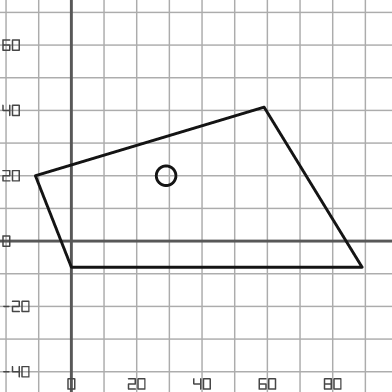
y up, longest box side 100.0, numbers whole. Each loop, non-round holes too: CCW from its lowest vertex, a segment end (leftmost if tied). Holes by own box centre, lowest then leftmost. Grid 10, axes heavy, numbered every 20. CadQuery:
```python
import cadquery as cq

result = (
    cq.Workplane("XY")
    .moveTo(0.0, -8.0)
    .lineTo(89.0, -8.0)
    .lineTo(59.0, 41.0)
    .lineTo(-11.0, 20.0)
    .close()
    .moveTo(29.0, 20.0)
    .circle(3.0)
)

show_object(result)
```